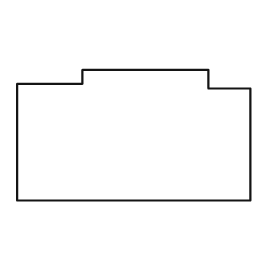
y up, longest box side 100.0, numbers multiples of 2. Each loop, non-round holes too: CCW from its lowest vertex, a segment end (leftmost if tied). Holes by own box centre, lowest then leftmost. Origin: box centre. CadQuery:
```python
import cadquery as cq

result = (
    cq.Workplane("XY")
    .moveTo(-50.0, -28.0)
    .lineTo(50.0, -28.0)
    .lineTo(50.0, 20.0)
    .lineTo(32.0, 20.0)
    .lineTo(32.0, 28.0)
    .lineTo(-22.0, 28.0)
    .lineTo(-22.0, 22.0)
    .lineTo(-50.0, 22.0)
    .close()
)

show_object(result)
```